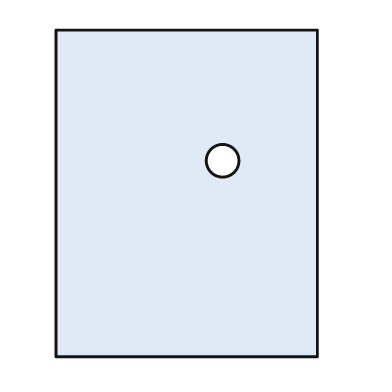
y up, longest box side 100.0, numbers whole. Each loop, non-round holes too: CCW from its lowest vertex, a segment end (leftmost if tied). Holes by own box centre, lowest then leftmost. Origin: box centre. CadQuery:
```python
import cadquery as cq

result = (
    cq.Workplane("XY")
    .moveTo(-40.0, -50.0)
    .lineTo(40.0, -50.0)
    .lineTo(40.0, 50.0)
    .lineTo(-40.0, 50.0)
    .close()
    .moveTo(11.0, 10.0)
    .circle(5.0)
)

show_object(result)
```